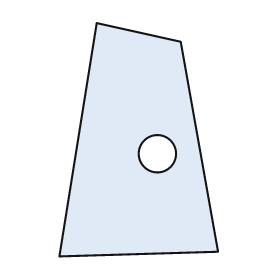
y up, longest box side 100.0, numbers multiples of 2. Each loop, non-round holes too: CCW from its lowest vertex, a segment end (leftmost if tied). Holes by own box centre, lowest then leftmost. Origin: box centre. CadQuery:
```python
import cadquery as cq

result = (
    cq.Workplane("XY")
    .moveTo(-34.0, -50.0)
    .lineTo(34.0, -48.0)
    .lineTo(18.0, 42.0)
    .lineTo(-18.0, 50.0)
    .close()
    .moveTo(8.0, -6.0)
    .circle(8.0)
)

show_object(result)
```